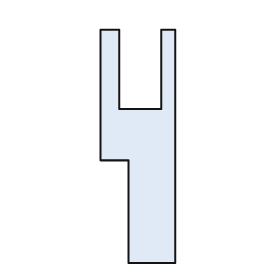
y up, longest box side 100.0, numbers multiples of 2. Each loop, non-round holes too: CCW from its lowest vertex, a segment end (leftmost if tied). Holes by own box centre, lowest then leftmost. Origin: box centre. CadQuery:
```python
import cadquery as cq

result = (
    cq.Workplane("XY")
    .moveTo(-4.0, -50.0)
    .lineTo(16.0, -50.0)
    .lineTo(16.0, 50.0)
    .lineTo(10.0, 50.0)
    .lineTo(10.0, 16.0)
    .lineTo(-8.0, 16.0)
    .lineTo(-8.0, 50.0)
    .lineTo(-16.0, 50.0)
    .lineTo(-16.0, -6.0)
    .lineTo(-4.0, -6.0)
    .close()
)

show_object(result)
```